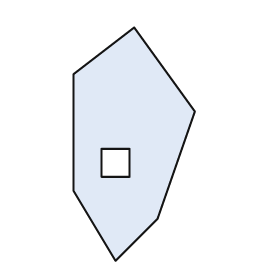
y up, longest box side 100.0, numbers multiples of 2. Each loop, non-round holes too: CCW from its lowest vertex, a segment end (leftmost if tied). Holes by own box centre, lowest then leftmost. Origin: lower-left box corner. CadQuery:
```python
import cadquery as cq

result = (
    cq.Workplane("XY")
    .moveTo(18.0, 0.0)
    .lineTo(36.0, 18.0)
    .lineTo(52.0, 64.0)
    .lineTo(26.0, 100.0)
    .lineTo(0.0, 80.0)
    .lineTo(0.0, 30.0)
    .close()
    .moveTo(12.0, 36.0)
    .lineTo(24.0, 36.0)
    .lineTo(24.0, 48.0)
    .lineTo(12.0, 48.0)
    .close()
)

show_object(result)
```